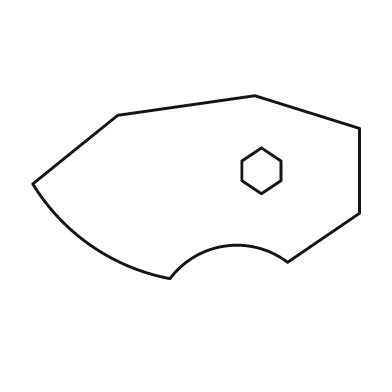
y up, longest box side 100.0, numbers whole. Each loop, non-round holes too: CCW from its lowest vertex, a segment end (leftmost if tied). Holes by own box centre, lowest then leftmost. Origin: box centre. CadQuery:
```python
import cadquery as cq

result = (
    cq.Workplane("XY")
    .moveTo(-8.0, -28.0)
    .threePointArc((9.0, -18.0), (28.0, -23.0))
    .lineTo(50.0, -8.0)
    .lineTo(50.0, 18.0)
    .lineTo(18.0, 28.0)
    .lineTo(-24.0, 22.0)
    .lineTo(-50.0, 1.0)
    .threePointArc((-32.0, -18.0), (-8.0, -28.0))
    .close()
    .moveTo(20.0, -2.0)
    .lineTo(26.0, 2.0)
    .lineTo(26.0, 8.0)
    .lineTo(20.0, 12.0)
    .lineTo(14.0, 8.0)
    .lineTo(14.0, 2.0)
    .close()
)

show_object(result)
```